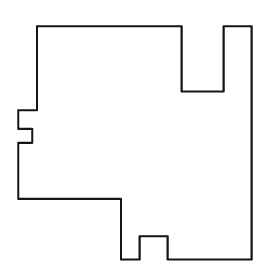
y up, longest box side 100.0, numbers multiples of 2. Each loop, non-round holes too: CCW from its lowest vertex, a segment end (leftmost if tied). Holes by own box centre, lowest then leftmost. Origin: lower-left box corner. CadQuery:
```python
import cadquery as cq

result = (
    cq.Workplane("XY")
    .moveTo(44.0, 0.0)
    .lineTo(52.0, 0.0)
    .lineTo(52.0, 10.0)
    .lineTo(64.0, 10.0)
    .lineTo(64.0, 0.0)
    .lineTo(100.0, 0.0)
    .lineTo(100.0, 100.0)
    .lineTo(88.0, 100.0)
    .lineTo(88.0, 72.0)
    .lineTo(70.0, 72.0)
    .lineTo(70.0, 100.0)
    .lineTo(8.0, 100.0)
    .lineTo(8.0, 64.0)
    .lineTo(0.0, 64.0)
    .lineTo(0.0, 56.0)
    .lineTo(6.0, 56.0)
    .lineTo(6.0, 50.0)
    .lineTo(0.0, 50.0)
    .lineTo(0.0, 26.0)
    .lineTo(44.0, 26.0)
    .close()
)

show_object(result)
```